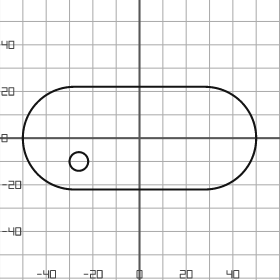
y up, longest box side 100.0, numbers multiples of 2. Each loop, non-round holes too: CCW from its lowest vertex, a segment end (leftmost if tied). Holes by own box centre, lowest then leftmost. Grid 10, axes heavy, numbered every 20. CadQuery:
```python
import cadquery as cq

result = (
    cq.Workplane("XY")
    .moveTo(-28.0, -22.0)
    .lineTo(28.0, -22.0)
    .threePointArc((50.0, 0.0), (28.0, 22.0))
    .lineTo(-28.0, 22.0)
    .threePointArc((-50.0, 0.0), (-28.0, -22.0))
    .close()
    .moveTo(-26.0, -10.0)
    .circle(4.0)
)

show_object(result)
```